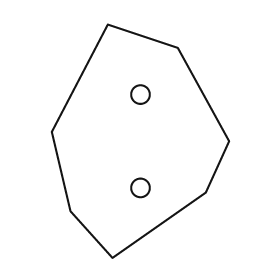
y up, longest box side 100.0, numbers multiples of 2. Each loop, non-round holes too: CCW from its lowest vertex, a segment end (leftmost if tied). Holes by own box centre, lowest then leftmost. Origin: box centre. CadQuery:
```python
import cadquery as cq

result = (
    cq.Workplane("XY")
    .moveTo(-12.0, -50.0)
    .lineTo(28.0, -22.0)
    .lineTo(38.0, 0.0)
    .lineTo(16.0, 40.0)
    .lineTo(-14.0, 50.0)
    .lineTo(-38.0, 4.0)
    .lineTo(-30.0, -30.0)
    .close()
    .moveTo(0.0, -20.0)
    .circle(4.0)
    .moveTo(0.0, 20.0)
    .circle(4.0)
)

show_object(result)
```